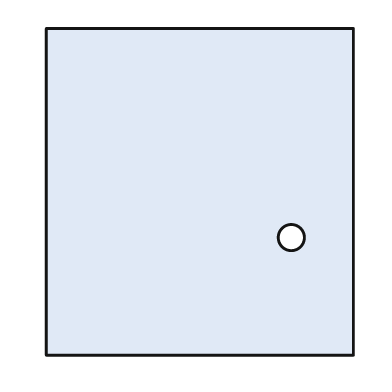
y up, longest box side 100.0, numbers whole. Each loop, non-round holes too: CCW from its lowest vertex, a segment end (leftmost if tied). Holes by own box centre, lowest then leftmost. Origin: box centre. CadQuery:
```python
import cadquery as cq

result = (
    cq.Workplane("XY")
    .moveTo(-47.0, -50.0)
    .lineTo(47.0, -50.0)
    .lineTo(47.0, 50.0)
    .lineTo(-47.0, 50.0)
    .close()
    .moveTo(28.0, -14.0)
    .circle(4.0)
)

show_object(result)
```